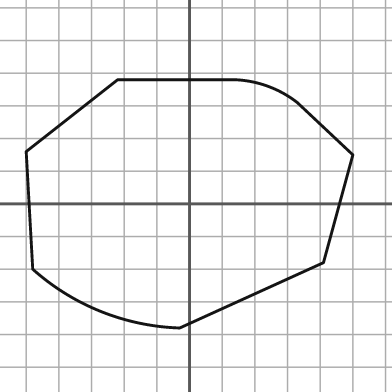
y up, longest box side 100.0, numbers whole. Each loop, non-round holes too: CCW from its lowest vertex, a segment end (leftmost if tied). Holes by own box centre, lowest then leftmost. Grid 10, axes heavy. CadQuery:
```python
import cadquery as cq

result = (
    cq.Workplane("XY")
    .moveTo(-3.0, -38.0)
    .lineTo(41.0, -18.0)
    .lineTo(50.0, 15.0)
    .lineTo(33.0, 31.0)
    .threePointArc((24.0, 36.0), (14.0, 38.0))
    .lineTo(-22.0, 38.0)
    .lineTo(-50.0, 16.0)
    .lineTo(-48.0, -20.0)
    .threePointArc((-27.0, -33.0), (-3.0, -38.0))
    .close()
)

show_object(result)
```